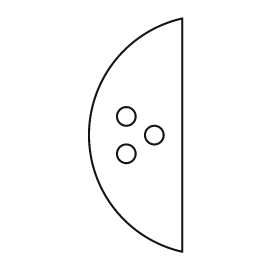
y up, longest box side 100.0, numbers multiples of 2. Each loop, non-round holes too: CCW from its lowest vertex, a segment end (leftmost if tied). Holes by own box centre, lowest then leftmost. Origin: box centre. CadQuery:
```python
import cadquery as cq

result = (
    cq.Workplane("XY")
    .moveTo(20.0, -50.0)
    .lineTo(20.0, 50.0)
    .threePointArc((-20.0, 0.0), (20.0, -50.0))
    .close()
    .moveTo(-4.0, -8.0)
    .circle(4.0)
    .moveTo(8.0, 0.0)
    .circle(4.0)
    .moveTo(-4.0, 8.0)
    .circle(4.0)
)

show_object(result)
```